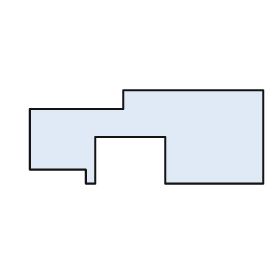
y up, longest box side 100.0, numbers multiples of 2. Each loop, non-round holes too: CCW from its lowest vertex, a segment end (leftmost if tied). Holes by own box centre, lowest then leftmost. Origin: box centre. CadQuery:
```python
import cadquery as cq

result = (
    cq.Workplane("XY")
    .moveTo(-26.0, -20.0)
    .lineTo(-22.0, -20.0)
    .lineTo(-22.0, 0.0)
    .lineTo(8.0, 0.0)
    .lineTo(8.0, -20.0)
    .lineTo(50.0, -20.0)
    .lineTo(50.0, 20.0)
    .lineTo(-10.0, 20.0)
    .lineTo(-10.0, 12.0)
    .lineTo(-50.0, 12.0)
    .lineTo(-50.0, -14.0)
    .lineTo(-26.0, -14.0)
    .close()
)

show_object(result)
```